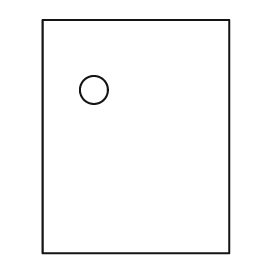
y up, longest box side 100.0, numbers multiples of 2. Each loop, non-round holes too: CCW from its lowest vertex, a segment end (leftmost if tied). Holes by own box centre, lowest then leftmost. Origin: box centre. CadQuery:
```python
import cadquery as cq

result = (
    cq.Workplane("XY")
    .moveTo(-40.0, -50.0)
    .lineTo(40.0, -50.0)
    .lineTo(40.0, 50.0)
    .lineTo(-40.0, 50.0)
    .close()
    .moveTo(-18.0, 20.0)
    .circle(6.0)
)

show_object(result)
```